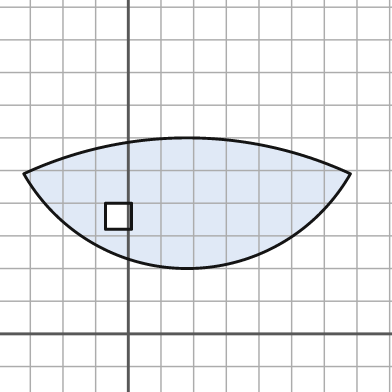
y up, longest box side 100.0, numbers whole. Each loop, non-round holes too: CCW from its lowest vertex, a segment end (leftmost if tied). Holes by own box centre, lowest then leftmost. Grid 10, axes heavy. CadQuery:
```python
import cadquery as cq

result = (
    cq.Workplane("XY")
    .moveTo(-32.0, 49.0)
    .threePointArc((18.0, 20.0), (68.0, 49.0))
    .threePointArc((18.0, 60.0), (-32.0, 49.0))
    .close()
    .moveTo(-7.0, 32.0)
    .lineTo(1.0, 32.0)
    .lineTo(1.0, 40.0)
    .lineTo(-7.0, 40.0)
    .close()
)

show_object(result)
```